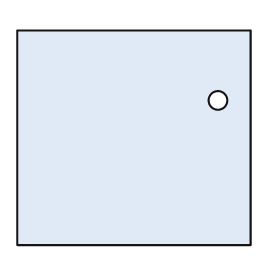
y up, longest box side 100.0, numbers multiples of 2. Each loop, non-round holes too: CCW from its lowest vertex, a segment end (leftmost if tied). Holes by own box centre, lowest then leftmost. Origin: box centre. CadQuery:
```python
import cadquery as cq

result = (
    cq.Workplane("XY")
    .moveTo(-50.0, -46.0)
    .lineTo(50.0, -46.0)
    .lineTo(50.0, 46.0)
    .lineTo(-50.0, 46.0)
    .close()
    .moveTo(36.0, 16.0)
    .circle(4.0)
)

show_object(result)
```